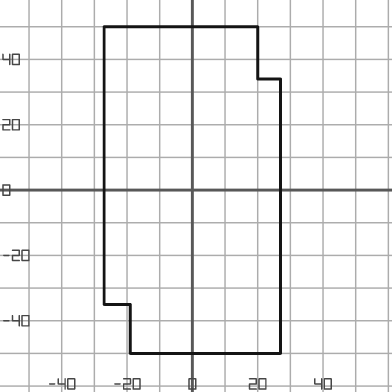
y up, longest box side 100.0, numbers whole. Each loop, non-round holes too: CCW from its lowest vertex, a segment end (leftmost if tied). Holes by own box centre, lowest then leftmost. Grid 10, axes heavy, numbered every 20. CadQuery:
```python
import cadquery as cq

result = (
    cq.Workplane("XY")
    .moveTo(-19.0, -50.0)
    .lineTo(27.0, -50.0)
    .lineTo(27.0, 34.0)
    .lineTo(20.0, 34.0)
    .lineTo(20.0, 50.0)
    .lineTo(-27.0, 50.0)
    .lineTo(-27.0, -35.0)
    .lineTo(-19.0, -35.0)
    .close()
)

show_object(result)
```